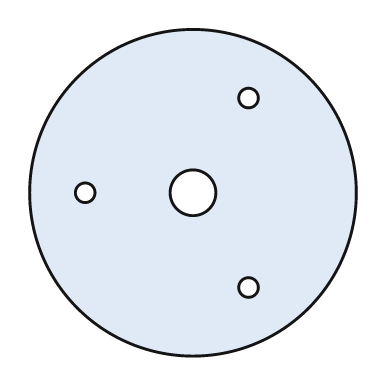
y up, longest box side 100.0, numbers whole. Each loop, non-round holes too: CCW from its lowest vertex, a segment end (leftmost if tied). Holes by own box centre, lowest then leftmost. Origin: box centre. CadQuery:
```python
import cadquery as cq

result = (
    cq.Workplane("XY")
    .moveTo(0.0, 0.0)
    .circle(50.0)
    .moveTo(17.0, -29.0)
    .circle(3.0)
    .moveTo(-33.0, 0.0)
    .circle(3.0)
    .moveTo(0.0, 0.0)
    .circle(7.0)
    .moveTo(17.0, 29.0)
    .circle(3.0)
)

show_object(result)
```